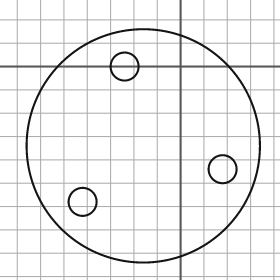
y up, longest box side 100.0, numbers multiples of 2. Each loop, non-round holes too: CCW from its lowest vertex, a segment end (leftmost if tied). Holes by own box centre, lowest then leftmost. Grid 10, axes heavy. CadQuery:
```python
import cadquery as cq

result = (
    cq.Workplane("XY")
    .moveTo(-16.0, -34.0)
    .circle(50.0)
    .moveTo(-42.0, -58.0)
    .circle(6.0)
    .moveTo(18.0, -44.0)
    .circle(6.0)
    .moveTo(-24.0, 0.0)
    .circle(6.0)
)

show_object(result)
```